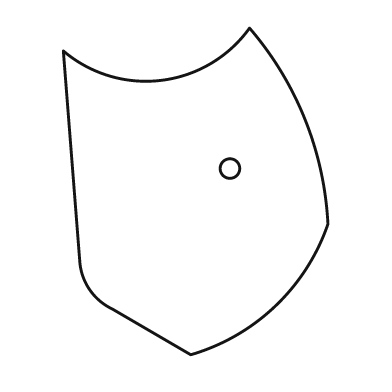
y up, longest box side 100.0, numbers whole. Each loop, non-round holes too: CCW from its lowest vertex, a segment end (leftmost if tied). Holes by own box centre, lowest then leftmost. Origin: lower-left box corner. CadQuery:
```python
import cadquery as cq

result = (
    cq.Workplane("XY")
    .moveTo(39.0, 0.0)
    .threePointArc((65.0, 15.0), (81.0, 40.0))
    .threePointArc((74.0, 72.0), (57.0, 100.0))
    .threePointArc((30.0, 84.0), (0.0, 93.0))
    .lineTo(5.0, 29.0)
    .threePointArc((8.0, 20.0), (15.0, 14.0))
    .close()
    .moveTo(51.0, 57.0)
    .circle(3.0)
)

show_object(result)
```